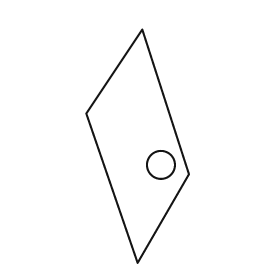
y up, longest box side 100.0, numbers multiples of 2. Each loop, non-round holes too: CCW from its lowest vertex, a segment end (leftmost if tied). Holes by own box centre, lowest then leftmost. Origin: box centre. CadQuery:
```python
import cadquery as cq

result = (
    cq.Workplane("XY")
    .moveTo(0.0, -50.0)
    .lineTo(22.0, -12.0)
    .lineTo(2.0, 50.0)
    .lineTo(-22.0, 14.0)
    .close()
    .moveTo(10.0, -8.0)
    .circle(6.0)
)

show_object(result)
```